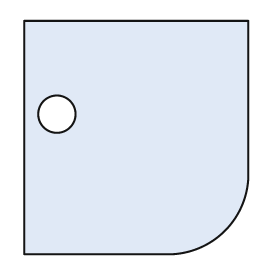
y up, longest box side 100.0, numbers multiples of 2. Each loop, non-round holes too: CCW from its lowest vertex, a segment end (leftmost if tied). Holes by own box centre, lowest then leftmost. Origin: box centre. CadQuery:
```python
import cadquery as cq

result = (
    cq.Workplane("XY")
    .moveTo(-48.0, -50.0)
    .lineTo(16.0, -50.0)
    .threePointArc((38.0, -40.0), (48.0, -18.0))
    .lineTo(48.0, 50.0)
    .lineTo(-48.0, 50.0)
    .close()
    .moveTo(-34.0, 10.0)
    .circle(8.0)
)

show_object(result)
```